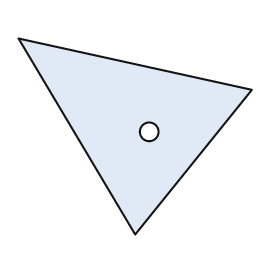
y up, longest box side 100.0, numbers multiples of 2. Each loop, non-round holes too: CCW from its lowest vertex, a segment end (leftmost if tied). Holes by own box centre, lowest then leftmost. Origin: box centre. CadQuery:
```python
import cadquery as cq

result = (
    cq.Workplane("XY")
    .moveTo(0.0, -42.0)
    .lineTo(50.0, 20.0)
    .lineTo(-50.0, 42.0)
    .close()
    .moveTo(6.0, 2.0)
    .circle(4.0)
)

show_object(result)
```